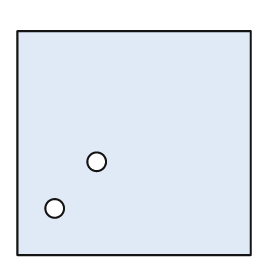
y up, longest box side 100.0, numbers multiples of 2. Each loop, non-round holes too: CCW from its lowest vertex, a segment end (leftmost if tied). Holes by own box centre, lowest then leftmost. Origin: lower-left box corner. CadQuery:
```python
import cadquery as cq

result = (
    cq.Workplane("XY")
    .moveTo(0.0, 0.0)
    .lineTo(100.0, 0.0)
    .lineTo(100.0, 96.0)
    .lineTo(0.0, 96.0)
    .close()
    .moveTo(16.0, 20.0)
    .circle(4.0)
    .moveTo(34.0, 40.0)
    .circle(4.0)
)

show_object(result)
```